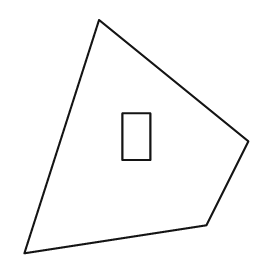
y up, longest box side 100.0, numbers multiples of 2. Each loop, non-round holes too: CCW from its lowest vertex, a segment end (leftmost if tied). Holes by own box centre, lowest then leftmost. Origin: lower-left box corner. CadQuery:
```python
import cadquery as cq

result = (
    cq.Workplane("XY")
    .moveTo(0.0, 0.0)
    .lineTo(78.0, 12.0)
    .lineTo(96.0, 48.0)
    .lineTo(32.0, 100.0)
    .close()
    .moveTo(42.0, 40.0)
    .lineTo(54.0, 40.0)
    .lineTo(54.0, 60.0)
    .lineTo(42.0, 60.0)
    .close()
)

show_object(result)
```